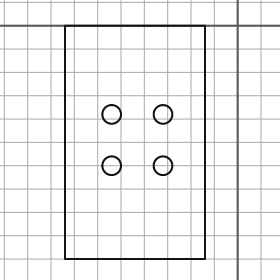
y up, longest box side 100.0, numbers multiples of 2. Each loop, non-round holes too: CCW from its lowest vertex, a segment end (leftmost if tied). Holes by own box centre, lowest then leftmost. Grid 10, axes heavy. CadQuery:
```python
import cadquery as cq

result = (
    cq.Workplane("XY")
    .moveTo(-74.0, -100.0)
    .lineTo(-14.0, -100.0)
    .lineTo(-14.0, 0.0)
    .lineTo(-74.0, 0.0)
    .close()
    .moveTo(-54.0, -60.0)
    .circle(4.0)
    .moveTo(-32.0, -60.0)
    .circle(4.0)
    .moveTo(-54.0, -38.0)
    .circle(4.0)
    .moveTo(-32.0, -38.0)
    .circle(4.0)
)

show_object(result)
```